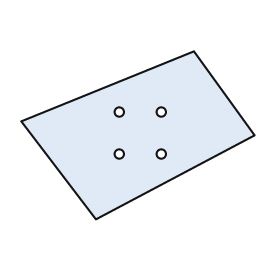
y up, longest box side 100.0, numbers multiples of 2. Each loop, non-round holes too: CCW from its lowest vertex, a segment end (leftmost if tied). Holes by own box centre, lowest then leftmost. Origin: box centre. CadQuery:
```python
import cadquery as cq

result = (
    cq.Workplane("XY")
    .moveTo(-18.0, -36.0)
    .lineTo(50.0, 0.0)
    .lineTo(24.0, 36.0)
    .lineTo(-50.0, 6.0)
    .close()
    .moveTo(-8.0, -8.0)
    .circle(2.0)
    .moveTo(10.0, -8.0)
    .circle(2.0)
    .moveTo(-8.0, 10.0)
    .circle(2.0)
    .moveTo(10.0, 10.0)
    .circle(2.0)
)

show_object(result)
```